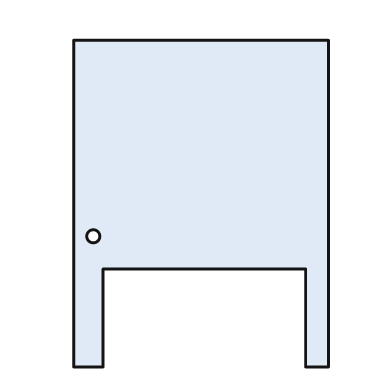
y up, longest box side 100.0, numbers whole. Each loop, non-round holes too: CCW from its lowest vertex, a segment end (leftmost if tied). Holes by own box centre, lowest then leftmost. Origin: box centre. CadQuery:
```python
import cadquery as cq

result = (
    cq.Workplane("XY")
    .moveTo(-39.0, -50.0)
    .lineTo(-30.0, -50.0)
    .lineTo(-30.0, -20.0)
    .lineTo(32.0, -20.0)
    .lineTo(32.0, -50.0)
    .lineTo(39.0, -50.0)
    .lineTo(39.0, 50.0)
    .lineTo(-39.0, 50.0)
    .close()
    .moveTo(-33.0, -10.0)
    .circle(2.0)
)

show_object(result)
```